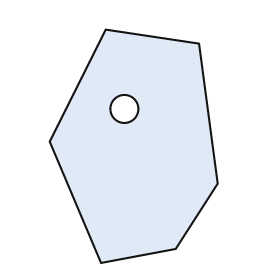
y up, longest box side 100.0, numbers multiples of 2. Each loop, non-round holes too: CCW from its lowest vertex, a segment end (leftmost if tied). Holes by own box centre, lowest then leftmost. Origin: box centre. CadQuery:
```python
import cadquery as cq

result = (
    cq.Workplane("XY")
    .moveTo(-14.0, -50.0)
    .lineTo(18.0, -44.0)
    .lineTo(36.0, -16.0)
    .lineTo(28.0, 44.0)
    .lineTo(-12.0, 50.0)
    .lineTo(-36.0, 2.0)
    .close()
    .moveTo(-4.0, 16.0)
    .circle(6.0)
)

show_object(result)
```